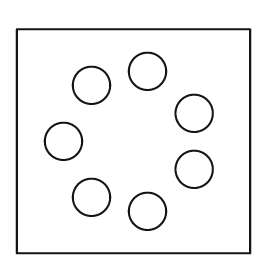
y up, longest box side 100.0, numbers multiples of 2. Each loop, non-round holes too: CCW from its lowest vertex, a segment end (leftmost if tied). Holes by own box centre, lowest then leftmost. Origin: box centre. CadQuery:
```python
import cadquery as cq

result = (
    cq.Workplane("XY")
    .moveTo(-50.0, -48.0)
    .lineTo(50.0, -48.0)
    .lineTo(50.0, 48.0)
    .lineTo(-50.0, 48.0)
    .close()
    .moveTo(6.0, -30.0)
    .circle(8.0)
    .moveTo(-18.0, -24.0)
    .circle(8.0)
    .moveTo(26.0, -12.0)
    .circle(8.0)
    .moveTo(-30.0, 0.0)
    .circle(8.0)
    .moveTo(26.0, 12.0)
    .circle(8.0)
    .moveTo(-18.0, 24.0)
    .circle(8.0)
    .moveTo(6.0, 30.0)
    .circle(8.0)
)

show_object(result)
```